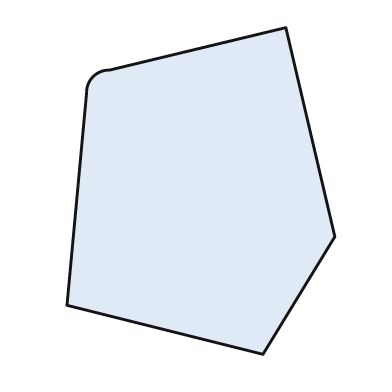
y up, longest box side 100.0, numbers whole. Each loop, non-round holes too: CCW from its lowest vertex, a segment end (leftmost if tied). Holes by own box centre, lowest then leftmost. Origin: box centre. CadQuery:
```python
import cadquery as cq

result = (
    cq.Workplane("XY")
    .moveTo(19.0, -50.0)
    .lineTo(41.0, -14.0)
    .lineTo(26.0, 50.0)
    .lineTo(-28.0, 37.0)
    .threePointArc((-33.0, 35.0), (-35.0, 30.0))
    .lineTo(-41.0, -35.0)
    .close()
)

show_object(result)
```